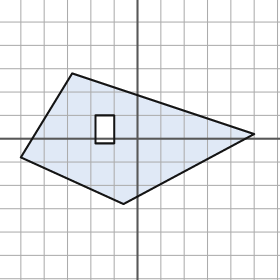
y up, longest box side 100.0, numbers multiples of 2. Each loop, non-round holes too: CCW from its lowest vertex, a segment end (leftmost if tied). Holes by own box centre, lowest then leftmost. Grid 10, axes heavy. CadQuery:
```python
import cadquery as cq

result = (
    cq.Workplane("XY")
    .moveTo(-6.0, -28.0)
    .lineTo(50.0, 2.0)
    .lineTo(-28.0, 28.0)
    .lineTo(-50.0, -8.0)
    .close()
    .moveTo(-18.0, -2.0)
    .lineTo(-10.0, -2.0)
    .lineTo(-10.0, 10.0)
    .lineTo(-18.0, 10.0)
    .close()
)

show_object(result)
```